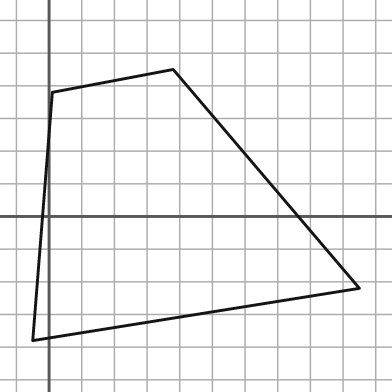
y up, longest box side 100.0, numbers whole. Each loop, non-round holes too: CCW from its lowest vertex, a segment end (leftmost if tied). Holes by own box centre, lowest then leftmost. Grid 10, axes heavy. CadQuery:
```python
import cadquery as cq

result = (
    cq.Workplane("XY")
    .moveTo(-5.0, -38.0)
    .lineTo(95.0, -22.0)
    .lineTo(38.0, 45.0)
    .lineTo(1.0, 38.0)
    .close()
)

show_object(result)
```